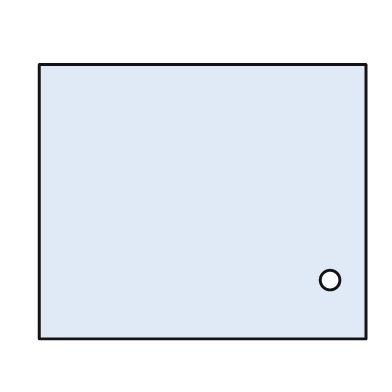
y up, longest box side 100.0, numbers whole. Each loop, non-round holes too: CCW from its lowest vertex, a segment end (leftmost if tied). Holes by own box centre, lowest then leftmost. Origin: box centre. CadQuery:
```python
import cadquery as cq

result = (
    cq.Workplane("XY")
    .moveTo(-50.0, -42.0)
    .lineTo(50.0, -42.0)
    .lineTo(50.0, 42.0)
    .lineTo(-50.0, 42.0)
    .close()
    .moveTo(39.0, -24.0)
    .circle(3.0)
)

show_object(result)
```